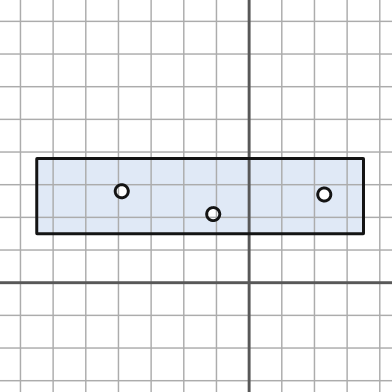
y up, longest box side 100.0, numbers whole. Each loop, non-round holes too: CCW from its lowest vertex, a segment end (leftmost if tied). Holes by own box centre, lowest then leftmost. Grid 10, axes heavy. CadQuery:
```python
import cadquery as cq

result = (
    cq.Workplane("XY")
    .moveTo(-65.0, 15.0)
    .lineTo(35.0, 15.0)
    .lineTo(35.0, 38.0)
    .lineTo(-65.0, 38.0)
    .close()
    .moveTo(-11.0, 21.0)
    .circle(2.0)
    .moveTo(23.0, 27.0)
    .circle(2.0)
    .moveTo(-39.0, 28.0)
    .circle(2.0)
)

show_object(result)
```